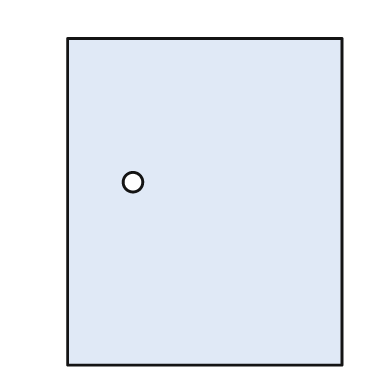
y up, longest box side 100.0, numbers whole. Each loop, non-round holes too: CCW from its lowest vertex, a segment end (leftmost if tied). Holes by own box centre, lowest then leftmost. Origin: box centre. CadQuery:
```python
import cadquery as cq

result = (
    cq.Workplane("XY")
    .moveTo(-42.0, -50.0)
    .lineTo(42.0, -50.0)
    .lineTo(42.0, 50.0)
    .lineTo(-42.0, 50.0)
    .close()
    .moveTo(-22.0, 6.0)
    .circle(3.0)
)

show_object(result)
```